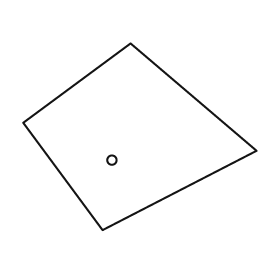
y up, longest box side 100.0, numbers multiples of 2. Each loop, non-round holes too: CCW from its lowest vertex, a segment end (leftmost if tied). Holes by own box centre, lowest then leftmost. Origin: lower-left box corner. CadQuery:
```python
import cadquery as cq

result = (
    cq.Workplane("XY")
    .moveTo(34.0, 0.0)
    .lineTo(100.0, 34.0)
    .lineTo(46.0, 80.0)
    .lineTo(0.0, 46.0)
    .close()
    .moveTo(38.0, 30.0)
    .circle(2.0)
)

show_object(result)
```